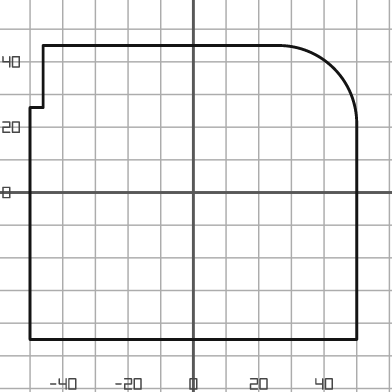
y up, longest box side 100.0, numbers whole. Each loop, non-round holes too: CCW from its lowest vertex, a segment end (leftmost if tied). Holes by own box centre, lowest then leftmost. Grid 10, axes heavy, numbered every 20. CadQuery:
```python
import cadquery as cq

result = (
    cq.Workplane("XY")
    .moveTo(-50.0, -45.0)
    .lineTo(50.0, -45.0)
    .lineTo(50.0, 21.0)
    .threePointArc((43.0, 38.0), (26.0, 45.0))
    .lineTo(-46.0, 45.0)
    .lineTo(-46.0, 26.0)
    .lineTo(-50.0, 26.0)
    .close()
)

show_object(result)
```